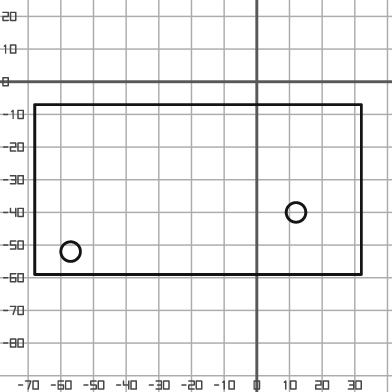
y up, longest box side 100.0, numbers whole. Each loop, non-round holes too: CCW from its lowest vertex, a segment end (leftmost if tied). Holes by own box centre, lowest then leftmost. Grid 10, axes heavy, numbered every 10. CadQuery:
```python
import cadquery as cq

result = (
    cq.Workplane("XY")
    .moveTo(-68.0, -59.0)
    .lineTo(32.0, -59.0)
    .lineTo(32.0, -7.0)
    .lineTo(-68.0, -7.0)
    .close()
    .moveTo(-57.0, -52.0)
    .circle(3.0)
    .moveTo(12.0, -40.0)
    .circle(3.0)
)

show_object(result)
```